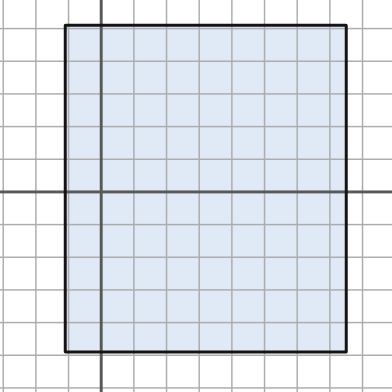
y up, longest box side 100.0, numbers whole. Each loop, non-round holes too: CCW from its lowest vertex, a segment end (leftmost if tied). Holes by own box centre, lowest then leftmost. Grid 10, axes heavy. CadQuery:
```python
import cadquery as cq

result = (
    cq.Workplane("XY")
    .moveTo(-11.0, -49.0)
    .lineTo(75.0, -49.0)
    .lineTo(75.0, 51.0)
    .lineTo(-11.0, 51.0)
    .close()
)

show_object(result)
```